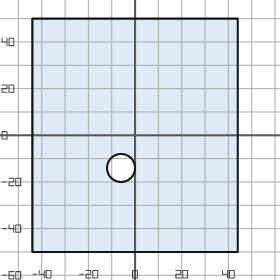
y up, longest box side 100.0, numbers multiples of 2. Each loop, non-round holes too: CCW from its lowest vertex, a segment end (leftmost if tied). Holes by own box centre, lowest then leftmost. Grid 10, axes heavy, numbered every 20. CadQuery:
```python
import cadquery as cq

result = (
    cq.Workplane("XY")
    .moveTo(-44.0, -50.0)
    .lineTo(44.0, -50.0)
    .lineTo(44.0, 50.0)
    .lineTo(-44.0, 50.0)
    .close()
    .moveTo(-6.0, -14.0)
    .circle(6.0)
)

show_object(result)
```